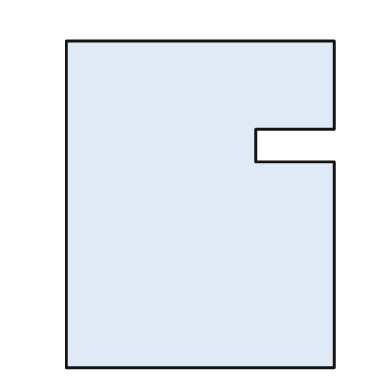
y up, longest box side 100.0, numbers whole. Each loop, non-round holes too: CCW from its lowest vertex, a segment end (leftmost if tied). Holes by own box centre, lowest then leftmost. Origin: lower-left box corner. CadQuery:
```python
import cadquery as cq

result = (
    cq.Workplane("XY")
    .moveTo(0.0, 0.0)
    .lineTo(82.0, 0.0)
    .lineTo(82.0, 63.0)
    .lineTo(58.0, 63.0)
    .lineTo(58.0, 73.0)
    .lineTo(82.0, 73.0)
    .lineTo(82.0, 100.0)
    .lineTo(0.0, 100.0)
    .close()
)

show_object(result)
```